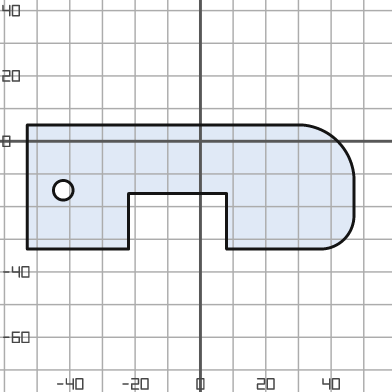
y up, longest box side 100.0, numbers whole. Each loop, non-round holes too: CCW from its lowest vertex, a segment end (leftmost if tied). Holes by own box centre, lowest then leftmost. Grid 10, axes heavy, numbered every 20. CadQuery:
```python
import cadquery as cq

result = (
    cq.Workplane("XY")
    .moveTo(-53.0, -33.0)
    .lineTo(-22.0, -33.0)
    .lineTo(-22.0, -16.0)
    .lineTo(8.0, -16.0)
    .lineTo(8.0, -33.0)
    .lineTo(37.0, -33.0)
    .threePointArc((44.0, -30.0), (47.0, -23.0))
    .lineTo(47.0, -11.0)
    .threePointArc((42.0, 0.0), (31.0, 5.0))
    .lineTo(-53.0, 5.0)
    .close()
    .moveTo(-42.0, -15.0)
    .circle(3.0)
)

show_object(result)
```